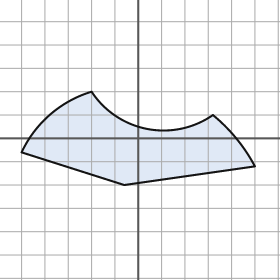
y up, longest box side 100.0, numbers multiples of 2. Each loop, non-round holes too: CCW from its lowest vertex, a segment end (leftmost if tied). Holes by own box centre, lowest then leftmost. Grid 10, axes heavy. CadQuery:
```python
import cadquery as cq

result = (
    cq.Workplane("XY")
    .moveTo(-6.0, -20.0)
    .lineTo(50.0, -12.0)
    .threePointArc((42.0, 0.0), (32.0, 10.0))
    .threePointArc((4.0, 4.0), (-20.0, 20.0))
    .threePointArc((-38.0, 10.0), (-50.0, -6.0))
    .close()
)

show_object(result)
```